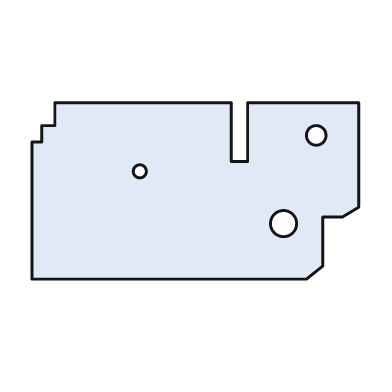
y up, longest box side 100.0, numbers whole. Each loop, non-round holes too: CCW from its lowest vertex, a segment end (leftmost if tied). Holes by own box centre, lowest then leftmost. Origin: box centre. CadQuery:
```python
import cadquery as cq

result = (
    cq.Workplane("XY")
    .moveTo(-50.0, -27.0)
    .lineTo(34.0, -27.0)
    .lineTo(39.0, -23.0)
    .lineTo(39.0, -8.0)
    .lineTo(45.0, -8.0)
    .lineTo(50.0, -5.0)
    .lineTo(50.0, 27.0)
    .lineTo(16.0, 27.0)
    .lineTo(16.0, 9.0)
    .lineTo(11.0, 9.0)
    .lineTo(11.0, 27.0)
    .lineTo(-43.0, 27.0)
    .lineTo(-43.0, 20.0)
    .lineTo(-47.0, 20.0)
    .lineTo(-47.0, 15.0)
    .lineTo(-50.0, 15.0)
    .close()
    .moveTo(27.0, -10.0)
    .circle(4.0)
    .moveTo(-17.0, 6.0)
    .circle(2.0)
    .moveTo(37.0, 17.0)
    .circle(3.0)
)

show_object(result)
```